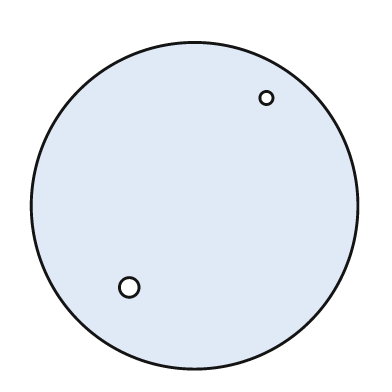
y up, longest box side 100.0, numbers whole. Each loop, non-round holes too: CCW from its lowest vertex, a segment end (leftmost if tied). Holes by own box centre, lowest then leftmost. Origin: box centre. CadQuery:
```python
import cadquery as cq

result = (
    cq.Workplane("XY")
    .moveTo(0.0, 0.0)
    .circle(50.0)
    .moveTo(-20.0, -25.0)
    .circle(3.0)
    .moveTo(22.0, 33.0)
    .circle(2.0)
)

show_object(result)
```